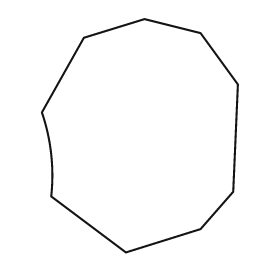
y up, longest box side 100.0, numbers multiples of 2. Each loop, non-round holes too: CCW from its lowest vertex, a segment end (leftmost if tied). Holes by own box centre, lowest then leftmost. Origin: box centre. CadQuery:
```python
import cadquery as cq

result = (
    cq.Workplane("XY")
    .moveTo(-6.0, -50.0)
    .lineTo(26.0, -40.0)
    .lineTo(40.0, -24.0)
    .lineTo(42.0, 22.0)
    .lineTo(26.0, 44.0)
    .lineTo(2.0, 50.0)
    .lineTo(-24.0, 42.0)
    .lineTo(-42.0, 10.0)
    .threePointArc((-38.0, -8.0), (-38.0, -26.0))
    .close()
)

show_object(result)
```